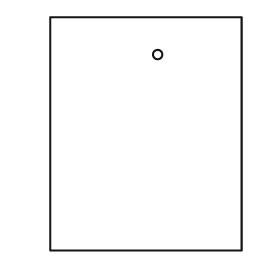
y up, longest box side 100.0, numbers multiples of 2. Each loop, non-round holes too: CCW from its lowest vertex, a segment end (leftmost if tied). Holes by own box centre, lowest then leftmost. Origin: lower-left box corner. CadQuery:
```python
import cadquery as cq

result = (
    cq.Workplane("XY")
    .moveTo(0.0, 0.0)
    .lineTo(82.0, 0.0)
    .lineTo(82.0, 100.0)
    .lineTo(0.0, 100.0)
    .close()
    .moveTo(46.0, 84.0)
    .circle(2.0)
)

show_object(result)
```